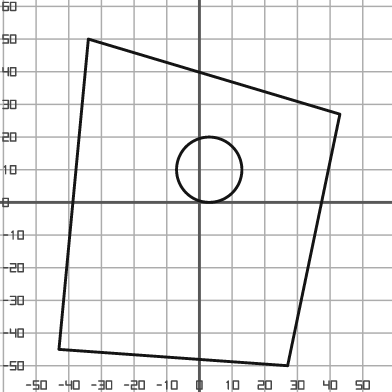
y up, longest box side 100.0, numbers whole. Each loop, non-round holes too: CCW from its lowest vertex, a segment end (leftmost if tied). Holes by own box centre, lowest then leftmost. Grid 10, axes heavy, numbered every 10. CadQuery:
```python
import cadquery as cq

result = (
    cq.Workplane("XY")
    .moveTo(27.0, -50.0)
    .lineTo(43.0, 27.0)
    .lineTo(-34.0, 50.0)
    .lineTo(-43.0, -45.0)
    .close()
    .moveTo(3.0, 10.0)
    .circle(10.0)
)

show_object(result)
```